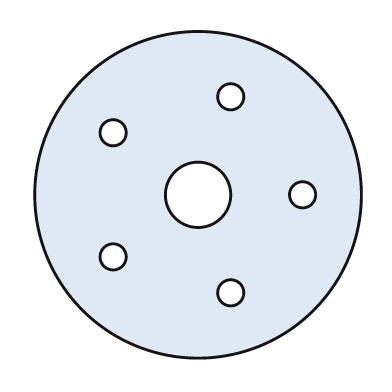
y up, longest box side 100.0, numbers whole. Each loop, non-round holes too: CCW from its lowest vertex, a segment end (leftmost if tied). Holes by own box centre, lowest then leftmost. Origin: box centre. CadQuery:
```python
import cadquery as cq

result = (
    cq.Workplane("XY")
    .moveTo(0.0, 0.0)
    .circle(50.0)
    .moveTo(10.0, -30.0)
    .circle(4.0)
    .moveTo(-26.0, -19.0)
    .circle(4.0)
    .moveTo(0.0, 0.0)
    .circle(10.0)
    .moveTo(32.0, 0.0)
    .circle(4.0)
    .moveTo(-26.0, 19.0)
    .circle(4.0)
    .moveTo(10.0, 30.0)
    .circle(4.0)
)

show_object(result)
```